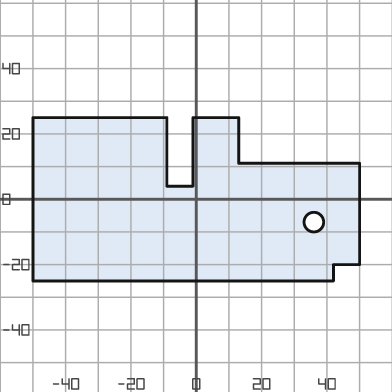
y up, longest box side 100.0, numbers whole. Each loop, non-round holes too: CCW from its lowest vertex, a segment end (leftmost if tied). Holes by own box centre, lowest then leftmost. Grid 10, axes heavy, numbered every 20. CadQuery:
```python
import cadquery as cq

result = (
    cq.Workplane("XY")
    .moveTo(-50.0, -25.0)
    .lineTo(42.0, -25.0)
    .lineTo(42.0, -20.0)
    .lineTo(50.0, -20.0)
    .lineTo(50.0, 11.0)
    .lineTo(13.0, 11.0)
    .lineTo(13.0, 25.0)
    .lineTo(-1.0, 25.0)
    .lineTo(-1.0, 4.0)
    .lineTo(-9.0, 4.0)
    .lineTo(-9.0, 25.0)
    .lineTo(-50.0, 25.0)
    .close()
    .moveTo(36.0, -7.0)
    .circle(3.0)
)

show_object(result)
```